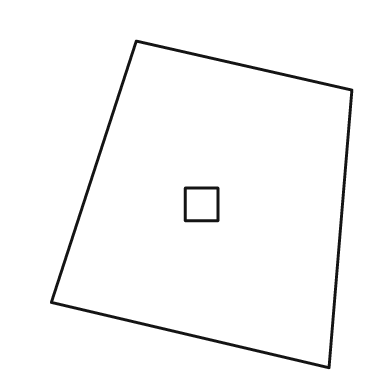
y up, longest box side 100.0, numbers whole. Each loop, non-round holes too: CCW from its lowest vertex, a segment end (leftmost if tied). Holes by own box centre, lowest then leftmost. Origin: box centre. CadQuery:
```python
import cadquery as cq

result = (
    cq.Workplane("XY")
    .moveTo(39.0, -50.0)
    .lineTo(46.0, 35.0)
    .lineTo(-20.0, 50.0)
    .lineTo(-46.0, -30.0)
    .close()
    .moveTo(-5.0, -5.0)
    .lineTo(5.0, -5.0)
    .lineTo(5.0, 5.0)
    .lineTo(-5.0, 5.0)
    .close()
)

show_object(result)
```